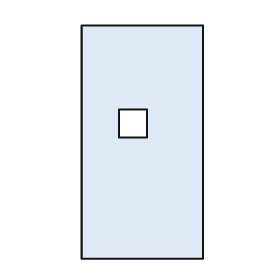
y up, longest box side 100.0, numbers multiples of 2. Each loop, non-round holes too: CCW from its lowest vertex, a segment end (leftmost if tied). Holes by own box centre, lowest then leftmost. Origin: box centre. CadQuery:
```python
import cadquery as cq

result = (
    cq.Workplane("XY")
    .moveTo(-26.0, -50.0)
    .lineTo(26.0, -50.0)
    .lineTo(26.0, 50.0)
    .lineTo(-26.0, 50.0)
    .close()
    .moveTo(-10.0, 2.0)
    .lineTo(2.0, 2.0)
    .lineTo(2.0, 14.0)
    .lineTo(-10.0, 14.0)
    .close()
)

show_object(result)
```